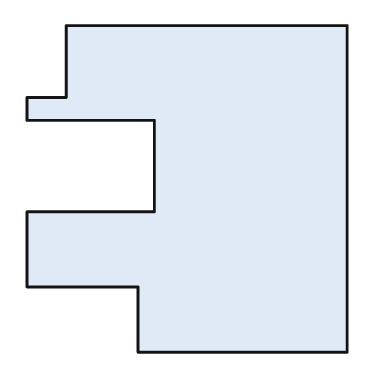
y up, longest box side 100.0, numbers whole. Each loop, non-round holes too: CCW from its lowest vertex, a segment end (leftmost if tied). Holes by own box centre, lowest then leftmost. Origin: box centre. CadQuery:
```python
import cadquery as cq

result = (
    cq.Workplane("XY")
    .moveTo(-15.0, -50.0)
    .lineTo(49.0, -50.0)
    .lineTo(49.0, 50.0)
    .lineTo(-37.0, 50.0)
    .lineTo(-37.0, 28.0)
    .lineTo(-49.0, 28.0)
    .lineTo(-49.0, 21.0)
    .lineTo(-10.0, 21.0)
    .lineTo(-10.0, -7.0)
    .lineTo(-49.0, -7.0)
    .lineTo(-49.0, -30.0)
    .lineTo(-15.0, -30.0)
    .close()
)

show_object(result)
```